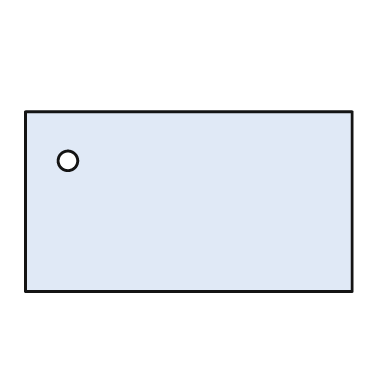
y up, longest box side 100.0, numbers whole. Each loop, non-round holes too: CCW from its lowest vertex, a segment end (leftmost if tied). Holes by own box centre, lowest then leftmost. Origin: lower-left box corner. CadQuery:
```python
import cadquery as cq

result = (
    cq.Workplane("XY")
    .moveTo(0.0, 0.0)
    .lineTo(100.0, 0.0)
    .lineTo(100.0, 55.0)
    .lineTo(0.0, 55.0)
    .close()
    .moveTo(13.0, 40.0)
    .circle(3.0)
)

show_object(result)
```